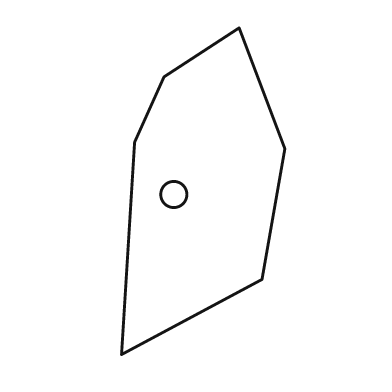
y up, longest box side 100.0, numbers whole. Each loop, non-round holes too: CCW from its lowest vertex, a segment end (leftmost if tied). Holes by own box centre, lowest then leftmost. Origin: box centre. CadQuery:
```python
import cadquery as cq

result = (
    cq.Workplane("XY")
    .moveTo(-25.0, -50.0)
    .lineTo(18.0, -27.0)
    .lineTo(25.0, 13.0)
    .lineTo(11.0, 50.0)
    .lineTo(-12.0, 35.0)
    .lineTo(-21.0, 15.0)
    .close()
    .moveTo(-9.0, -1.0)
    .circle(4.0)
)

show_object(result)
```